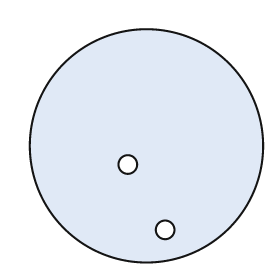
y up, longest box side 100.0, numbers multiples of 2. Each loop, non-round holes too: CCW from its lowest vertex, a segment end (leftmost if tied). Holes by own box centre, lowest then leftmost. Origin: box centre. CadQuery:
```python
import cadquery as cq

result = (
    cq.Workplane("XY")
    .moveTo(0.0, 0.0)
    .circle(50.0)
    .moveTo(8.0, -36.0)
    .circle(4.0)
    .moveTo(-8.0, -8.0)
    .circle(4.0)
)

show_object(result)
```